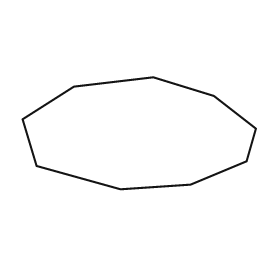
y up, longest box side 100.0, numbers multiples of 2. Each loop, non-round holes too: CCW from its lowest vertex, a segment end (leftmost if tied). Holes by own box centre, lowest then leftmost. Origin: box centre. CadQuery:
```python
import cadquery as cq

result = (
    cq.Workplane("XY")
    .moveTo(-8.0, -24.0)
    .lineTo(22.0, -22.0)
    .lineTo(46.0, -12.0)
    .lineTo(50.0, 2.0)
    .lineTo(32.0, 16.0)
    .lineTo(6.0, 24.0)
    .lineTo(-28.0, 20.0)
    .lineTo(-50.0, 6.0)
    .lineTo(-44.0, -14.0)
    .close()
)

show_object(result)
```